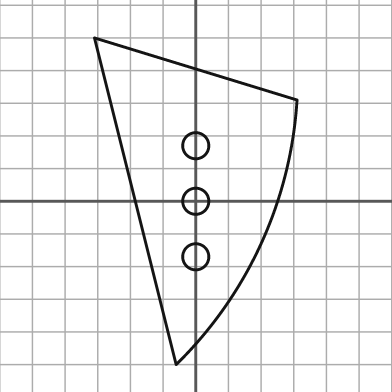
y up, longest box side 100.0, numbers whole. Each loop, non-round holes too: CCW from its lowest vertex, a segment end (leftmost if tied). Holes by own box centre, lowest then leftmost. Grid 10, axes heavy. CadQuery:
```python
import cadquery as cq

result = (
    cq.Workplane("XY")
    .moveTo(-6.0, -50.0)
    .threePointArc((20.0, -13.0), (31.0, 31.0))
    .lineTo(-31.0, 50.0)
    .close()
    .moveTo(0.0, -17.0)
    .circle(4.0)
    .moveTo(0.0, 0.0)
    .circle(4.0)
    .moveTo(0.0, 17.0)
    .circle(4.0)
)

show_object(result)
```